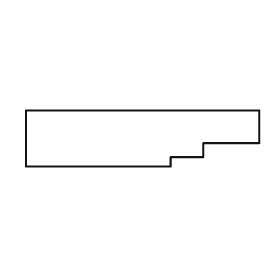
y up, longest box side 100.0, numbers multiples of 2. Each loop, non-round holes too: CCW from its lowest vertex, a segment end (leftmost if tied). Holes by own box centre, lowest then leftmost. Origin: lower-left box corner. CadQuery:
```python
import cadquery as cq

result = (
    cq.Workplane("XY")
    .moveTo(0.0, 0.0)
    .lineTo(62.0, 0.0)
    .lineTo(62.0, 4.0)
    .lineTo(76.0, 4.0)
    .lineTo(76.0, 10.0)
    .lineTo(100.0, 10.0)
    .lineTo(100.0, 24.0)
    .lineTo(0.0, 24.0)
    .close()
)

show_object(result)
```